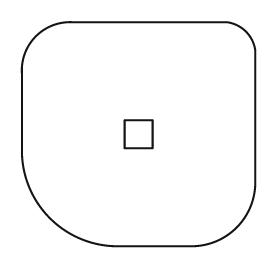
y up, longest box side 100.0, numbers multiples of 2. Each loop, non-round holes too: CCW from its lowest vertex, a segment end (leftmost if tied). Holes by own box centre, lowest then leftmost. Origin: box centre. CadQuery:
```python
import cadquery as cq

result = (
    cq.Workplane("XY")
    .moveTo(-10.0, -48.0)
    .lineTo(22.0, -48.0)
    .threePointArc((42.0, -40.0), (50.0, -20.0))
    .lineTo(50.0, 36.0)
    .threePointArc((46.0, 44.0), (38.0, 48.0))
    .lineTo(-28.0, 48.0)
    .threePointArc((-44.0, 42.0), (-50.0, 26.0))
    .lineTo(-50.0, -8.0)
    .threePointArc((-38.0, -36.0), (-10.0, -48.0))
    .close()
    .moveTo(-6.0, -6.0)
    .lineTo(6.0, -6.0)
    .lineTo(6.0, 6.0)
    .lineTo(-6.0, 6.0)
    .close()
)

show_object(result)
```